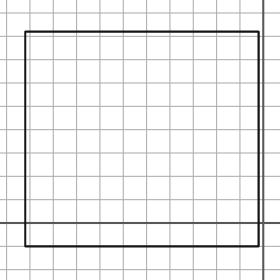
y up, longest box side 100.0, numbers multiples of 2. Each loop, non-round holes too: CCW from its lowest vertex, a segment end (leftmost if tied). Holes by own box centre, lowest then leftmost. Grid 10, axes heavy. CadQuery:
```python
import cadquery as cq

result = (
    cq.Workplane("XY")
    .moveTo(-102.0, -10.0)
    .lineTo(-2.0, -10.0)
    .lineTo(-2.0, 82.0)
    .lineTo(-102.0, 82.0)
    .close()
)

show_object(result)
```